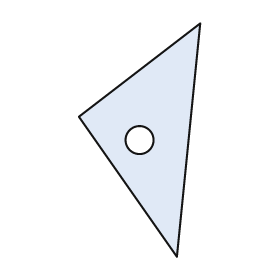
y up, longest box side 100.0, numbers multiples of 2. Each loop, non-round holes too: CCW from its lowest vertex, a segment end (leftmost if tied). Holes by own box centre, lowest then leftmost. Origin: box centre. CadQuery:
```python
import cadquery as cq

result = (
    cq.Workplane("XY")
    .moveTo(16.0, -50.0)
    .lineTo(26.0, 50.0)
    .lineTo(-26.0, 10.0)
    .close()
    .moveTo(0.0, 0.0)
    .circle(6.0)
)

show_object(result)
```